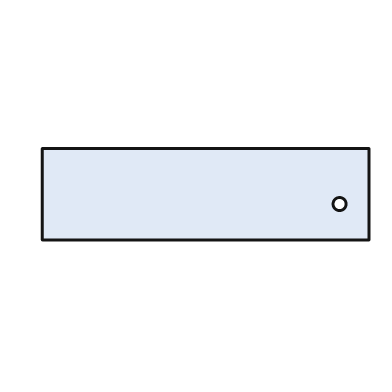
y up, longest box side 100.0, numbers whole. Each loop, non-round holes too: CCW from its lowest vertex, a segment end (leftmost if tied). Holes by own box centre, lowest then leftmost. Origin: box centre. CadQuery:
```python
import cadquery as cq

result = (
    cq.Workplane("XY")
    .moveTo(-50.0, -14.0)
    .lineTo(50.0, -14.0)
    .lineTo(50.0, 14.0)
    .lineTo(-50.0, 14.0)
    .close()
    .moveTo(41.0, -3.0)
    .circle(2.0)
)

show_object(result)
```